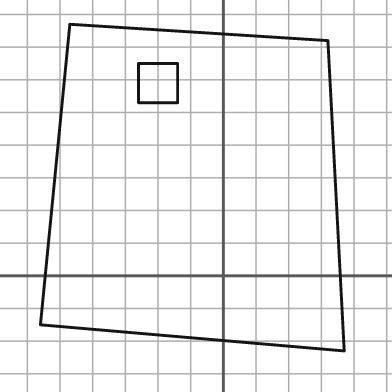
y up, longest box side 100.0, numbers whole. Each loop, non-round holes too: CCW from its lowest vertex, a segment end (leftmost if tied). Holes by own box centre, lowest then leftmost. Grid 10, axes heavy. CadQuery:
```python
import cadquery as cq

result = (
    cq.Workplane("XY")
    .moveTo(37.0, -23.0)
    .lineTo(32.0, 72.0)
    .lineTo(-47.0, 77.0)
    .lineTo(-56.0, -15.0)
    .close()
    .moveTo(-26.0, 53.0)
    .lineTo(-14.0, 53.0)
    .lineTo(-14.0, 65.0)
    .lineTo(-26.0, 65.0)
    .close()
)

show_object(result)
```